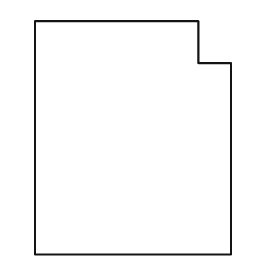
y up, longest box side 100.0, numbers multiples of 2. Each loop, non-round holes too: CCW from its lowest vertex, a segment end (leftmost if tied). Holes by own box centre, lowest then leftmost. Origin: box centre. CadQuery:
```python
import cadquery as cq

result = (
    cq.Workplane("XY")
    .moveTo(-42.0, -50.0)
    .lineTo(42.0, -50.0)
    .lineTo(42.0, 32.0)
    .lineTo(28.0, 32.0)
    .lineTo(28.0, 50.0)
    .lineTo(-42.0, 50.0)
    .close()
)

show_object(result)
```